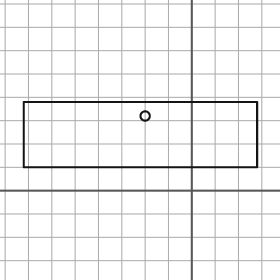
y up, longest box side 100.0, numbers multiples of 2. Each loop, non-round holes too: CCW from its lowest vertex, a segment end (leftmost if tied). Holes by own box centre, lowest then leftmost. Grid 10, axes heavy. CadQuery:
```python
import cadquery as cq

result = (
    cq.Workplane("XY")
    .moveTo(-72.0, 10.0)
    .lineTo(28.0, 10.0)
    .lineTo(28.0, 38.0)
    .lineTo(-72.0, 38.0)
    .close()
    .moveTo(-20.0, 32.0)
    .circle(2.0)
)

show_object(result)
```